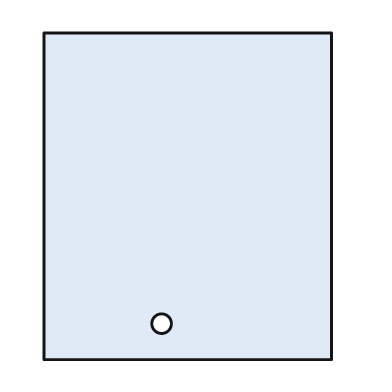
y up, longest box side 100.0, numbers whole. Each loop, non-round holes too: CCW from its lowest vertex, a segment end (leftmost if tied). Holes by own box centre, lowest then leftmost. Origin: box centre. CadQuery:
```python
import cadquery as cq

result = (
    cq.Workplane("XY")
    .moveTo(-44.0, -50.0)
    .lineTo(44.0, -50.0)
    .lineTo(44.0, 50.0)
    .lineTo(-44.0, 50.0)
    .close()
    .moveTo(-8.0, -39.0)
    .circle(3.0)
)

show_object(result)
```